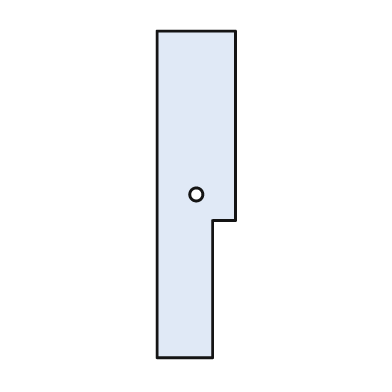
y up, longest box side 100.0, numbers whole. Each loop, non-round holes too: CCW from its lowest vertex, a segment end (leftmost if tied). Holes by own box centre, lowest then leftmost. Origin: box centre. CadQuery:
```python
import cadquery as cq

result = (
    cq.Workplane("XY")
    .moveTo(-12.0, -50.0)
    .lineTo(5.0, -50.0)
    .lineTo(5.0, -8.0)
    .lineTo(12.0, -8.0)
    .lineTo(12.0, 50.0)
    .lineTo(-12.0, 50.0)
    .close()
    .moveTo(0.0, 0.0)
    .circle(2.0)
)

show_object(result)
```